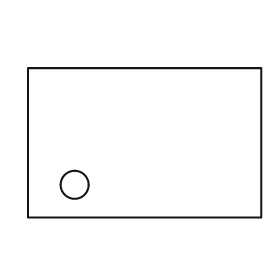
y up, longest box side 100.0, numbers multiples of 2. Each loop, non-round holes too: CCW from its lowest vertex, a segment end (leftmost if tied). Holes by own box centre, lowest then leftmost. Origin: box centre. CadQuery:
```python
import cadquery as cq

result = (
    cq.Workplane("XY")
    .moveTo(-50.0, -32.0)
    .lineTo(50.0, -32.0)
    .lineTo(50.0, 32.0)
    .lineTo(-50.0, 32.0)
    .close()
    .moveTo(-30.0, -18.0)
    .circle(6.0)
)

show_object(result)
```